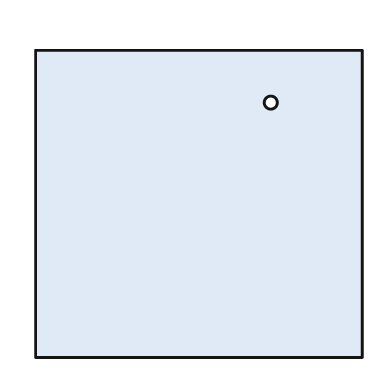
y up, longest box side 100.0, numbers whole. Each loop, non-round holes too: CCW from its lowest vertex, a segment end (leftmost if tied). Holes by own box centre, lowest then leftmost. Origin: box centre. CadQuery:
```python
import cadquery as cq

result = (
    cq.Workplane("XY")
    .moveTo(-50.0, -47.0)
    .lineTo(50.0, -47.0)
    .lineTo(50.0, 47.0)
    .lineTo(-50.0, 47.0)
    .close()
    .moveTo(22.0, 31.0)
    .circle(2.0)
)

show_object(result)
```